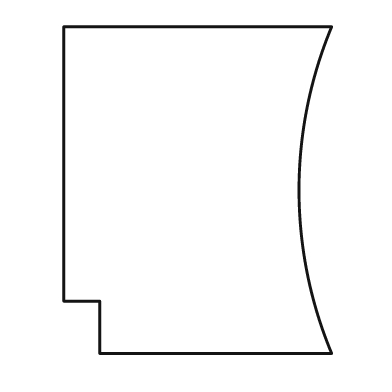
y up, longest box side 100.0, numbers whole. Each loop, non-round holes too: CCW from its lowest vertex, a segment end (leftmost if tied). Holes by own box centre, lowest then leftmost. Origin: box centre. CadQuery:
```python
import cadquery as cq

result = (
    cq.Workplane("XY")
    .moveTo(-30.0, -50.0)
    .lineTo(41.0, -50.0)
    .threePointArc((31.0, 0.0), (41.0, 50.0))
    .lineTo(-41.0, 50.0)
    .lineTo(-41.0, -34.0)
    .lineTo(-30.0, -34.0)
    .close()
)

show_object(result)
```